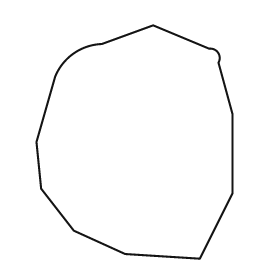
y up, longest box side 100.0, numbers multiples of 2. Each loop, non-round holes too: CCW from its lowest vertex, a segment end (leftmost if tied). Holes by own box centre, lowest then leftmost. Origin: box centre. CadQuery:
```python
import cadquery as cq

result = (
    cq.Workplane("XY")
    .moveTo(28.0, -50.0)
    .lineTo(42.0, -22.0)
    .lineTo(42.0, 12.0)
    .lineTo(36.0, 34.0)
    .threePointArc((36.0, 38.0), (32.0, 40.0))
    .lineTo(8.0, 50.0)
    .lineTo(-14.0, 42.0)
    .threePointArc((-26.0, 38.0), (-34.0, 28.0))
    .lineTo(-42.0, 0.0)
    .lineTo(-40.0, -20.0)
    .lineTo(-26.0, -38.0)
    .lineTo(-4.0, -48.0)
    .close()
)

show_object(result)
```